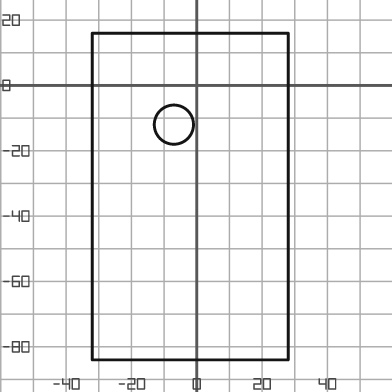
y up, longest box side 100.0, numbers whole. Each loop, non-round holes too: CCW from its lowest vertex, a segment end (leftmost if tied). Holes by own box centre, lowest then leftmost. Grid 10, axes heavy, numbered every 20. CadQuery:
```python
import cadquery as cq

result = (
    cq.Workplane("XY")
    .moveTo(-32.0, -84.0)
    .lineTo(28.0, -84.0)
    .lineTo(28.0, 16.0)
    .lineTo(-32.0, 16.0)
    .close()
    .moveTo(-7.0, -12.0)
    .circle(6.0)
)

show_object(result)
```